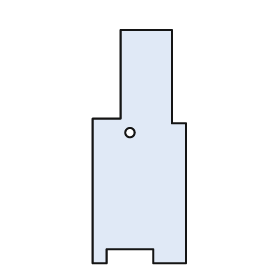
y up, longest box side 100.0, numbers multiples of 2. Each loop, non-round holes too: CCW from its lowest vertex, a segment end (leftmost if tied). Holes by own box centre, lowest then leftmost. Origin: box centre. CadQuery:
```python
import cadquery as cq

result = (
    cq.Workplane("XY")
    .moveTo(-20.0, -50.0)
    .lineTo(-14.0, -50.0)
    .lineTo(-14.0, -44.0)
    .lineTo(6.0, -44.0)
    .lineTo(6.0, -50.0)
    .lineTo(20.0, -50.0)
    .lineTo(20.0, 10.0)
    .lineTo(14.0, 10.0)
    .lineTo(14.0, 50.0)
    .lineTo(-8.0, 50.0)
    .lineTo(-8.0, 12.0)
    .lineTo(-20.0, 12.0)
    .close()
    .moveTo(-4.0, 6.0)
    .circle(2.0)
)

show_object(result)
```